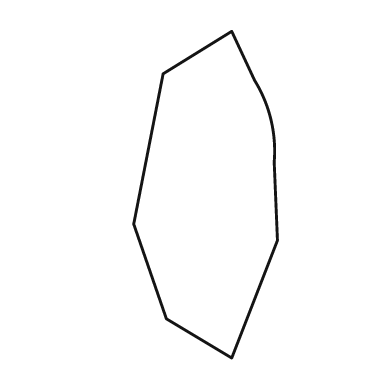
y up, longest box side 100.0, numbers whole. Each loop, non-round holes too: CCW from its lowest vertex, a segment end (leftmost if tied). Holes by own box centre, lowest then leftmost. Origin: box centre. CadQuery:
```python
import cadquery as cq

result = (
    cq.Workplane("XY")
    .moveTo(8.0, -50.0)
    .lineTo(22.0, -14.0)
    .lineTo(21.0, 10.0)
    .threePointArc((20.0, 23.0), (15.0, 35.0))
    .lineTo(8.0, 50.0)
    .lineTo(-13.0, 37.0)
    .lineTo(-22.0, -9.0)
    .lineTo(-12.0, -38.0)
    .close()
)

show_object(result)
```